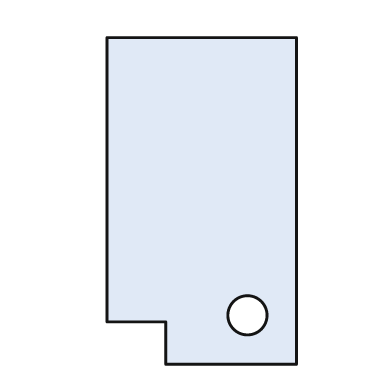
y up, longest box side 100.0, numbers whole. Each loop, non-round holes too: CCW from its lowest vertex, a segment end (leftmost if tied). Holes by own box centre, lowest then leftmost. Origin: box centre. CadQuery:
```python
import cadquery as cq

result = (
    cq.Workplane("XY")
    .moveTo(-11.0, -50.0)
    .lineTo(29.0, -50.0)
    .lineTo(29.0, 50.0)
    .lineTo(-29.0, 50.0)
    .lineTo(-29.0, -37.0)
    .lineTo(-11.0, -37.0)
    .close()
    .moveTo(14.0, -35.0)
    .circle(6.0)
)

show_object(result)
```